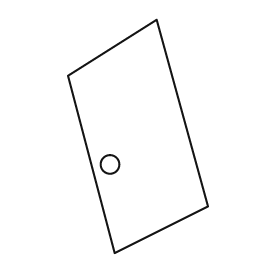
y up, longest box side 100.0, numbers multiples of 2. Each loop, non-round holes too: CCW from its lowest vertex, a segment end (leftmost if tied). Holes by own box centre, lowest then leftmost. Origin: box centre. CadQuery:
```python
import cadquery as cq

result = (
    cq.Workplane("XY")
    .moveTo(-10.0, -50.0)
    .lineTo(30.0, -30.0)
    .lineTo(8.0, 50.0)
    .lineTo(-30.0, 26.0)
    .close()
    .moveTo(-12.0, -12.0)
    .circle(4.0)
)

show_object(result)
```